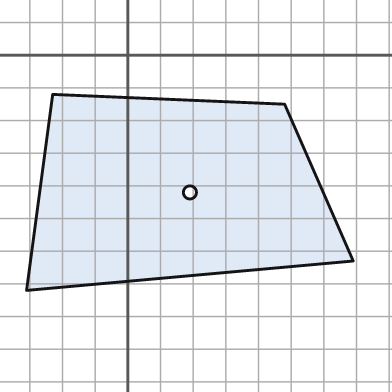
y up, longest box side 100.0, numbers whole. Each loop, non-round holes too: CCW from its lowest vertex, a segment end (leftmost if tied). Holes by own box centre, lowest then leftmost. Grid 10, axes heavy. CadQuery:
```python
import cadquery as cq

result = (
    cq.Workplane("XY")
    .moveTo(-31.0, -72.0)
    .lineTo(69.0, -63.0)
    .lineTo(48.0, -15.0)
    .lineTo(-23.0, -12.0)
    .close()
    .moveTo(19.0, -42.0)
    .circle(2.0)
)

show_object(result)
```